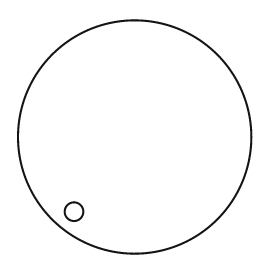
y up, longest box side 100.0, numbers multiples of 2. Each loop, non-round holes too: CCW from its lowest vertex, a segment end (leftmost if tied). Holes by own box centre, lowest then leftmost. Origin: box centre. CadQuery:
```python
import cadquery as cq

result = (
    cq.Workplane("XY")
    .moveTo(0.0, 0.0)
    .circle(50.0)
    .moveTo(-26.0, -32.0)
    .circle(4.0)
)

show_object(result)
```